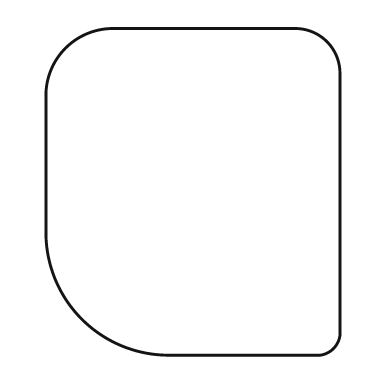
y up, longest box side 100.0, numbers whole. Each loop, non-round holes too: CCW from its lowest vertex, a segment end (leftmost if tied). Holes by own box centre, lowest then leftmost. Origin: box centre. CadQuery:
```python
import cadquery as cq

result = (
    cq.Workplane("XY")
    .moveTo(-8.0, -50.0)
    .lineTo(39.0, -50.0)
    .threePointArc((43.0, -48.0), (45.0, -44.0))
    .lineTo(45.0, 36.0)
    .threePointArc((41.0, 46.0), (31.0, 50.0))
    .lineTo(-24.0, 50.0)
    .threePointArc((-39.0, 44.0), (-45.0, 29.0))
    .lineTo(-45.0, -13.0)
    .threePointArc((-34.0, -39.0), (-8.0, -50.0))
    .close()
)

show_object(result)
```